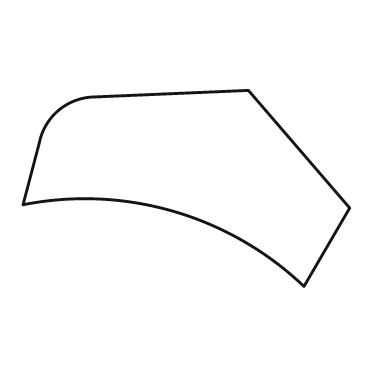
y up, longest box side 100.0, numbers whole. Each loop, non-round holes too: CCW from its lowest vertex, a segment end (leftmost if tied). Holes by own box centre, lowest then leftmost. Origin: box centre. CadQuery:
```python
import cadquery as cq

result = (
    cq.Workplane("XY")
    .moveTo(36.0, -30.0)
    .lineTo(50.0, -6.0)
    .lineTo(19.0, 30.0)
    .lineTo(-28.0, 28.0)
    .threePointArc((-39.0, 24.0), (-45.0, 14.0))
    .lineTo(-50.0, -5.0)
    .threePointArc((-4.0, -7.0), (36.0, -30.0))
    .close()
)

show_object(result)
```